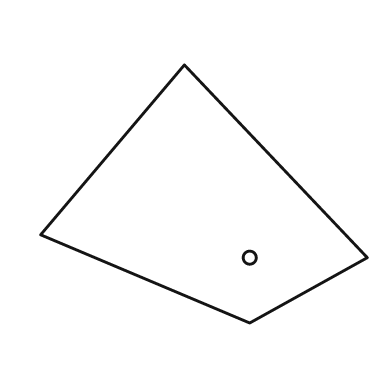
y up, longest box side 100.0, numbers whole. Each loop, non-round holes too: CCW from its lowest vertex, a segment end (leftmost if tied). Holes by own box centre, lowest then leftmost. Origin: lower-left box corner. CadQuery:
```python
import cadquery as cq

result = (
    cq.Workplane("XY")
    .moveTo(64.0, 0.0)
    .lineTo(100.0, 20.0)
    .lineTo(44.0, 79.0)
    .lineTo(0.0, 27.0)
    .close()
    .moveTo(64.0, 20.0)
    .circle(2.0)
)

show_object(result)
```